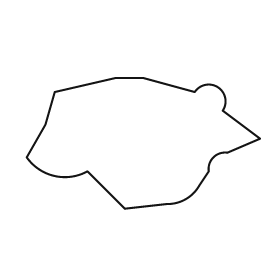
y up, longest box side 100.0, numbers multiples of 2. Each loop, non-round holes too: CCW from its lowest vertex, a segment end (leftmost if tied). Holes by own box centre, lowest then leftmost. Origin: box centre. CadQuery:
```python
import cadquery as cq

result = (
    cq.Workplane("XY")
    .moveTo(-8.0, -28.0)
    .lineTo(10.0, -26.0)
    .threePointArc((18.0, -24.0), (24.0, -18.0))
    .lineTo(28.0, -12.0)
    .threePointArc((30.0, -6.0), (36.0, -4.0))
    .lineTo(50.0, 2.0)
    .lineTo(34.0, 14.0)
    .threePointArc((32.0, 24.0), (22.0, 22.0))
    .lineTo(0.0, 28.0)
    .lineTo(-12.0, 28.0)
    .lineTo(-38.0, 22.0)
    .lineTo(-42.0, 8.0)
    .lineTo(-50.0, -6.0)
    .threePointArc((-38.0, -14.0), (-24.0, -12.0))
    .close()
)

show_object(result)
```